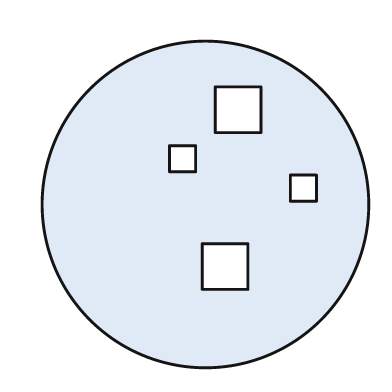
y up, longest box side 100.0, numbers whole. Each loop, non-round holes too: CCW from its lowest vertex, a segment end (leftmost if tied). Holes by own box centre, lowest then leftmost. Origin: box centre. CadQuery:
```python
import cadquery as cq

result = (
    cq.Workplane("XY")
    .moveTo(0.0, 0.0)
    .circle(50.0)
    .moveTo(-1.0, -26.0)
    .lineTo(13.0, -26.0)
    .lineTo(13.0, -12.0)
    .lineTo(-1.0, -12.0)
    .close()
    .moveTo(26.0, 1.0)
    .lineTo(34.0, 1.0)
    .lineTo(34.0, 9.0)
    .lineTo(26.0, 9.0)
    .close()
    .moveTo(-11.0, 10.0)
    .lineTo(-3.0, 10.0)
    .lineTo(-3.0, 18.0)
    .lineTo(-11.0, 18.0)
    .close()
    .moveTo(3.0, 22.0)
    .lineTo(17.0, 22.0)
    .lineTo(17.0, 36.0)
    .lineTo(3.0, 36.0)
    .close()
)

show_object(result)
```